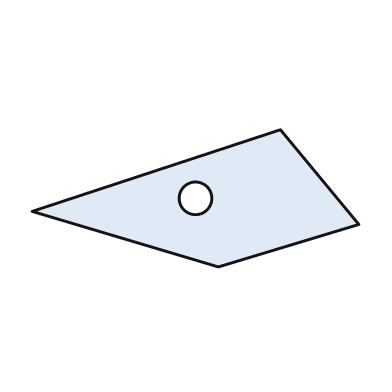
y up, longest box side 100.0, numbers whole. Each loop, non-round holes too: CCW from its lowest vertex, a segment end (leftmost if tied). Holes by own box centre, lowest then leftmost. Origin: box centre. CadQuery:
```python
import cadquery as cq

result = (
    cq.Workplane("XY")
    .moveTo(7.0, -21.0)
    .lineTo(50.0, -8.0)
    .lineTo(26.0, 21.0)
    .lineTo(-50.0, -4.0)
    .close()
    .moveTo(0.0, 0.0)
    .circle(5.0)
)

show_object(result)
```